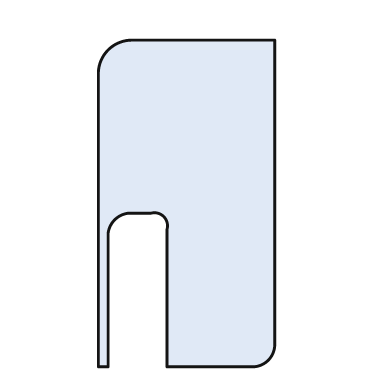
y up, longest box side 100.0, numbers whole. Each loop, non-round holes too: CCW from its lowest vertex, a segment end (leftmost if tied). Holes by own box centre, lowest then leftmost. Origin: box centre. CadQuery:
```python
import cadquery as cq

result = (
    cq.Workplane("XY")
    .moveTo(-27.0, -50.0)
    .lineTo(-24.0, -50.0)
    .lineTo(-24.0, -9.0)
    .threePointArc((-22.0, -5.0), (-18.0, -3.0))
    .lineTo(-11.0, -3.0)
    .threePointArc((-7.0, -4.0), (-6.0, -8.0))
    .lineTo(-6.0, -50.0)
    .lineTo(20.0, -50.0)
    .threePointArc((25.0, -48.0), (27.0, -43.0))
    .lineTo(27.0, 50.0)
    .lineTo(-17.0, 50.0)
    .threePointArc((-24.0, 47.0), (-27.0, 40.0))
    .close()
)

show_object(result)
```